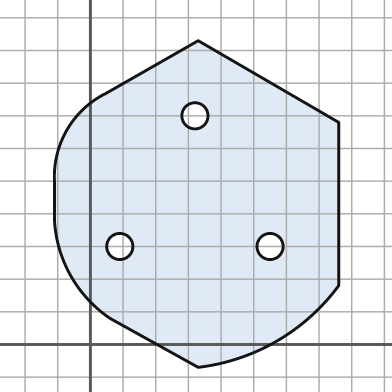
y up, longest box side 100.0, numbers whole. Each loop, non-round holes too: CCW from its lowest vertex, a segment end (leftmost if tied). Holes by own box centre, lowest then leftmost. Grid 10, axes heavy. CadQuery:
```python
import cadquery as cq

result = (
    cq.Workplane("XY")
    .moveTo(33.0, -7.0)
    .threePointArc((57.0, 1.0), (76.0, 18.0))
    .lineTo(76.0, 68.0)
    .lineTo(33.0, 93.0)
    .lineTo(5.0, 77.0)
    .threePointArc((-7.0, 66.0), (-11.0, 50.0))
    .lineTo(-11.0, 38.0)
    .threePointArc((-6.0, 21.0), (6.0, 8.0))
    .close()
    .moveTo(9.0, 30.0)
    .circle(4.0)
    .moveTo(55.0, 30.0)
    .circle(4.0)
    .moveTo(32.0, 70.0)
    .circle(4.0)
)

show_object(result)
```